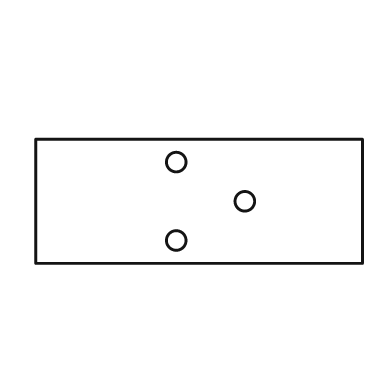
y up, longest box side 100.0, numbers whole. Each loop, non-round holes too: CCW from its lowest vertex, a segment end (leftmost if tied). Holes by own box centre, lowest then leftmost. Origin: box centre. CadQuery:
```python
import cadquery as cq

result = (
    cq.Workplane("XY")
    .moveTo(-50.0, -19.0)
    .lineTo(50.0, -19.0)
    .lineTo(50.0, 19.0)
    .lineTo(-50.0, 19.0)
    .close()
    .moveTo(-7.0, -12.0)
    .circle(3.0)
    .moveTo(14.0, 0.0)
    .circle(3.0)
    .moveTo(-7.0, 12.0)
    .circle(3.0)
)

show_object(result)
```